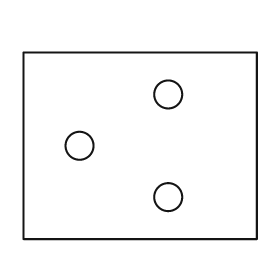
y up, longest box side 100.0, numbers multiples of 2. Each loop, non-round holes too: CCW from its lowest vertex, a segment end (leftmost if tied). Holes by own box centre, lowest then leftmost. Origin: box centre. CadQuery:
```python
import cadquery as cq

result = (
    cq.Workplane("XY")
    .moveTo(-50.0, -40.0)
    .lineTo(50.0, -40.0)
    .lineTo(50.0, 40.0)
    .lineTo(-50.0, 40.0)
    .close()
    .moveTo(12.0, -22.0)
    .circle(6.0)
    .moveTo(-26.0, 0.0)
    .circle(6.0)
    .moveTo(12.0, 22.0)
    .circle(6.0)
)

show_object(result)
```